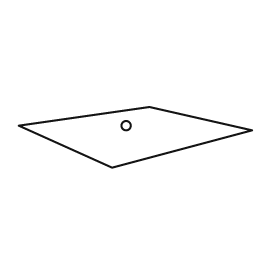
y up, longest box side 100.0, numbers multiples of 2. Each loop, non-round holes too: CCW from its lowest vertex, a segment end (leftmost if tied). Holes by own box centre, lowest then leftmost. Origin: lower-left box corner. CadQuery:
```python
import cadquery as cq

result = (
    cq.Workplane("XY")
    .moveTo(40.0, 0.0)
    .lineTo(100.0, 16.0)
    .lineTo(56.0, 26.0)
    .lineTo(0.0, 18.0)
    .close()
    .moveTo(46.0, 18.0)
    .circle(2.0)
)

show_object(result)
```